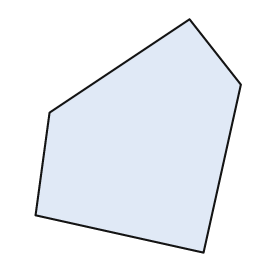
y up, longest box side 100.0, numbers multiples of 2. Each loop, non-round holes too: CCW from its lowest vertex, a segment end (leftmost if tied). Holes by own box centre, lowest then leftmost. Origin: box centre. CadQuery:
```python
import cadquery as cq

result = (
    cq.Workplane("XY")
    .moveTo(28.0, -50.0)
    .lineTo(44.0, 22.0)
    .lineTo(22.0, 50.0)
    .lineTo(-38.0, 10.0)
    .lineTo(-44.0, -34.0)
    .close()
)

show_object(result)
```